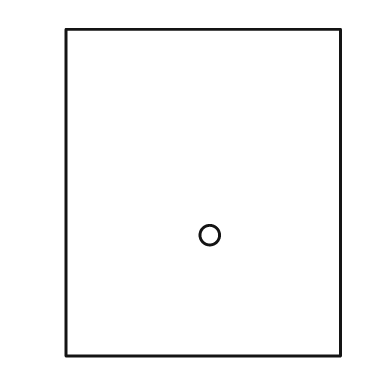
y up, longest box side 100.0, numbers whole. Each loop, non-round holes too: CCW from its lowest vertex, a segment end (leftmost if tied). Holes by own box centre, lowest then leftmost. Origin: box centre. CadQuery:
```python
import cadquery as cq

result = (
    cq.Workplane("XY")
    .moveTo(-42.0, -50.0)
    .lineTo(42.0, -50.0)
    .lineTo(42.0, 50.0)
    .lineTo(-42.0, 50.0)
    .close()
    .moveTo(2.0, -13.0)
    .circle(3.0)
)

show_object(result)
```